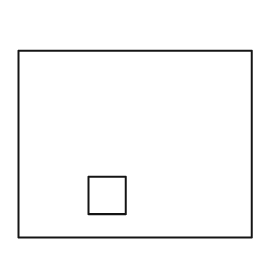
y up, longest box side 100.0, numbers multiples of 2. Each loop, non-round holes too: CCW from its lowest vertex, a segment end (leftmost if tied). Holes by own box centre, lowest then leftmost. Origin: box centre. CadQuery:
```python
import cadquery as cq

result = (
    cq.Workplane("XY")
    .moveTo(-50.0, -40.0)
    .lineTo(50.0, -40.0)
    .lineTo(50.0, 40.0)
    .lineTo(-50.0, 40.0)
    .close()
    .moveTo(-20.0, -30.0)
    .lineTo(-4.0, -30.0)
    .lineTo(-4.0, -14.0)
    .lineTo(-20.0, -14.0)
    .close()
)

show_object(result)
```